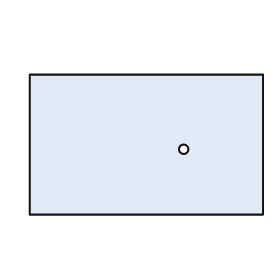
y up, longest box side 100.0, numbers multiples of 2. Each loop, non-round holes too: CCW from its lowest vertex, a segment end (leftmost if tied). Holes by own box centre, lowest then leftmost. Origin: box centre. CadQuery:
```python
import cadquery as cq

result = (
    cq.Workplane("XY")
    .moveTo(-50.0, -30.0)
    .lineTo(50.0, -30.0)
    .lineTo(50.0, 30.0)
    .lineTo(-50.0, 30.0)
    .close()
    .moveTo(16.0, -2.0)
    .circle(2.0)
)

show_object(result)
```